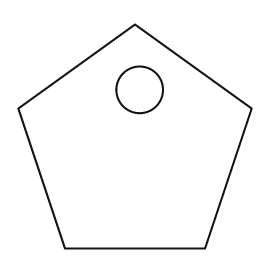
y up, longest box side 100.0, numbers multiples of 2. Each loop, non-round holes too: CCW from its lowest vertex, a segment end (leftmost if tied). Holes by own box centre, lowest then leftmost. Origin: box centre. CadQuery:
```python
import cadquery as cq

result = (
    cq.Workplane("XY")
    .moveTo(-30.0, -48.0)
    .lineTo(30.0, -48.0)
    .lineTo(50.0, 12.0)
    .lineTo(0.0, 48.0)
    .lineTo(-50.0, 12.0)
    .close()
    .moveTo(2.0, 20.0)
    .circle(10.0)
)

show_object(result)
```